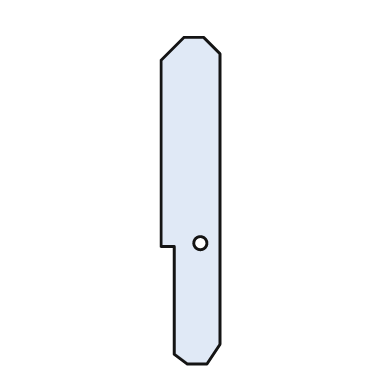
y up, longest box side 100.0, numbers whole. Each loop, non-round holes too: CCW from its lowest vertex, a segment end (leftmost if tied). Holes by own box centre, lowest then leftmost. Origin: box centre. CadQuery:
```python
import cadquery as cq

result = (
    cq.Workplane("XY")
    .moveTo(-1.0, -50.0)
    .lineTo(5.0, -50.0)
    .lineTo(9.0, -44.0)
    .lineTo(9.0, 45.0)
    .lineTo(4.0, 50.0)
    .lineTo(-2.0, 50.0)
    .lineTo(-9.0, 43.0)
    .lineTo(-9.0, -14.0)
    .lineTo(-5.0, -14.0)
    .lineTo(-5.0, -47.0)
    .close()
    .moveTo(3.0, -13.0)
    .circle(2.0)
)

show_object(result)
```